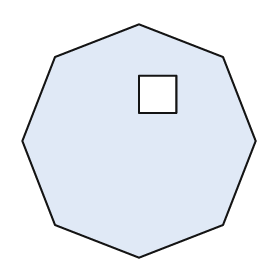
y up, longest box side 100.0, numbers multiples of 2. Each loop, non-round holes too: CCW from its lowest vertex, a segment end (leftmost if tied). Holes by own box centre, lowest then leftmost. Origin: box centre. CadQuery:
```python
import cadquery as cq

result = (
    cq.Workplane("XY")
    .moveTo(0.0, -50.0)
    .lineTo(36.0, -36.0)
    .lineTo(50.0, 0.0)
    .lineTo(36.0, 36.0)
    .lineTo(0.0, 50.0)
    .lineTo(-36.0, 36.0)
    .lineTo(-50.0, 0.0)
    .lineTo(-36.0, -36.0)
    .close()
    .moveTo(0.0, 12.0)
    .lineTo(16.0, 12.0)
    .lineTo(16.0, 28.0)
    .lineTo(0.0, 28.0)
    .close()
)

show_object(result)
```